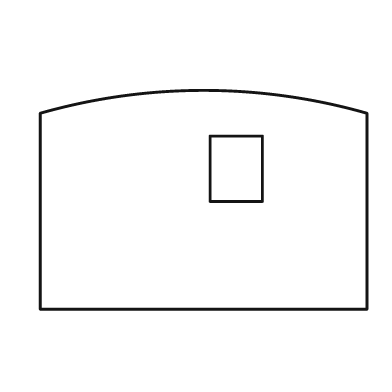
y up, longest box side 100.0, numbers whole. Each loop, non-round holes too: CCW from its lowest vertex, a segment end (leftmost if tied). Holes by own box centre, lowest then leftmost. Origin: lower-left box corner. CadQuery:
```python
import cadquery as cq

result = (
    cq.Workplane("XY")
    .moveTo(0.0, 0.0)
    .lineTo(100.0, 0.0)
    .lineTo(100.0, 60.0)
    .threePointArc((50.0, 67.0), (0.0, 60.0))
    .close()
    .moveTo(52.0, 33.0)
    .lineTo(68.0, 33.0)
    .lineTo(68.0, 53.0)
    .lineTo(52.0, 53.0)
    .close()
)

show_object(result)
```